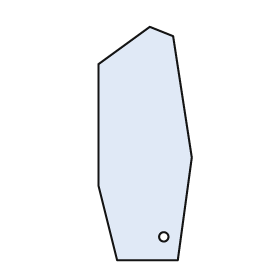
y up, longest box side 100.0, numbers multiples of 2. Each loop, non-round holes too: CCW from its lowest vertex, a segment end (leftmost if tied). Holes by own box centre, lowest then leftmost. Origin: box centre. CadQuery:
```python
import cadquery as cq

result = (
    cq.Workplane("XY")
    .moveTo(-12.0, -50.0)
    .lineTo(14.0, -50.0)
    .lineTo(20.0, -6.0)
    .lineTo(12.0, 46.0)
    .lineTo(2.0, 50.0)
    .lineTo(-20.0, 34.0)
    .lineTo(-20.0, -18.0)
    .close()
    .moveTo(8.0, -40.0)
    .circle(2.0)
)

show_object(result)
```